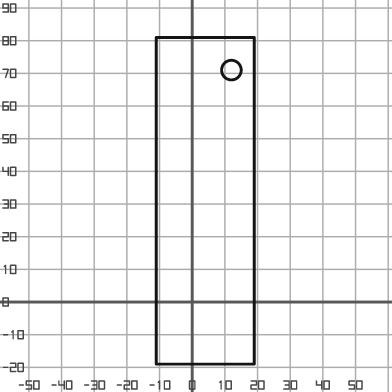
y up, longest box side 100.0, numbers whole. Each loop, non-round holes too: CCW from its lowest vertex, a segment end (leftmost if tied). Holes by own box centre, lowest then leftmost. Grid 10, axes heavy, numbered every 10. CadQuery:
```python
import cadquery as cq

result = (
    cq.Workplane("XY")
    .moveTo(-11.0, -19.0)
    .lineTo(19.0, -19.0)
    .lineTo(19.0, 81.0)
    .lineTo(-11.0, 81.0)
    .close()
    .moveTo(12.0, 71.0)
    .circle(3.0)
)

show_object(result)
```